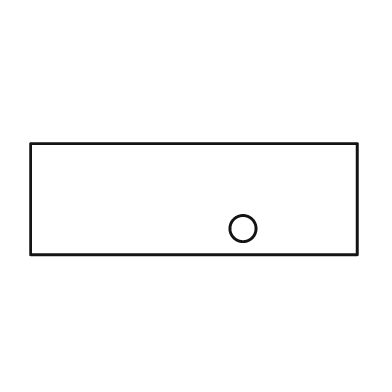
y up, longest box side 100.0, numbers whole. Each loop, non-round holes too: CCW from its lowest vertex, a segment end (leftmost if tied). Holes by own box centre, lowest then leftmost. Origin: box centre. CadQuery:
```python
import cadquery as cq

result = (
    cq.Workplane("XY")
    .moveTo(-50.0, -17.0)
    .lineTo(50.0, -17.0)
    .lineTo(50.0, 17.0)
    .lineTo(-50.0, 17.0)
    .close()
    .moveTo(15.0, -9.0)
    .circle(4.0)
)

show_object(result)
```